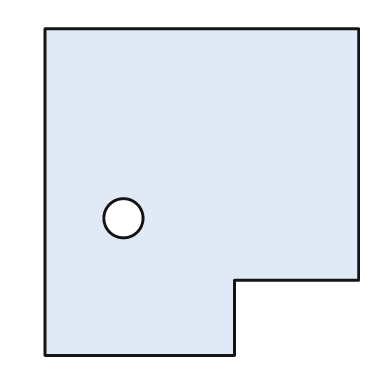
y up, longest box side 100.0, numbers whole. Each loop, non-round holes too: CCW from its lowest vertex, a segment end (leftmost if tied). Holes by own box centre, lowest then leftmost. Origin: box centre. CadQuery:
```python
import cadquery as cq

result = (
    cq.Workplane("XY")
    .moveTo(-48.0, -50.0)
    .lineTo(10.0, -50.0)
    .lineTo(10.0, -27.0)
    .lineTo(48.0, -27.0)
    .lineTo(48.0, 50.0)
    .lineTo(-48.0, 50.0)
    .close()
    .moveTo(-24.0, -8.0)
    .circle(6.0)
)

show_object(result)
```